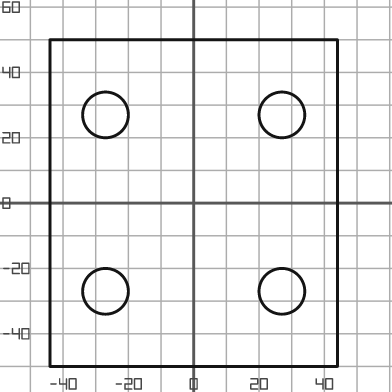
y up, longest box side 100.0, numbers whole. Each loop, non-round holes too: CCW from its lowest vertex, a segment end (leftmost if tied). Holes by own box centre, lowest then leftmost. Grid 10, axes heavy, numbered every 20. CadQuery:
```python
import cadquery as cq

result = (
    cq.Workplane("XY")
    .moveTo(-44.0, -50.0)
    .lineTo(44.0, -50.0)
    .lineTo(44.0, 50.0)
    .lineTo(-44.0, 50.0)
    .close()
    .moveTo(-27.0, -27.0)
    .circle(7.0)
    .moveTo(27.0, -27.0)
    .circle(7.0)
    .moveTo(-27.0, 27.0)
    .circle(7.0)
    .moveTo(27.0, 27.0)
    .circle(7.0)
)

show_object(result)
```